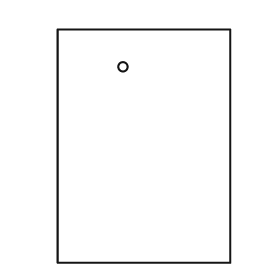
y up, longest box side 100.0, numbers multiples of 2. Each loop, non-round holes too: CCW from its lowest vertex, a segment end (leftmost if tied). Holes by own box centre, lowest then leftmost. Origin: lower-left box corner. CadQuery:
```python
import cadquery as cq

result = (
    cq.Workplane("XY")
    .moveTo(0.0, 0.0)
    .lineTo(74.0, 0.0)
    .lineTo(74.0, 100.0)
    .lineTo(0.0, 100.0)
    .close()
    .moveTo(28.0, 84.0)
    .circle(2.0)
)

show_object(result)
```